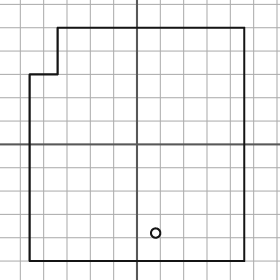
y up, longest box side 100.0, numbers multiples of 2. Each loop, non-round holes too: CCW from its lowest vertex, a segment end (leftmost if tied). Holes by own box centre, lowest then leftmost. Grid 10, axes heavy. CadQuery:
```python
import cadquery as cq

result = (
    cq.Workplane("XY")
    .moveTo(-46.0, -50.0)
    .lineTo(46.0, -50.0)
    .lineTo(46.0, 50.0)
    .lineTo(-34.0, 50.0)
    .lineTo(-34.0, 30.0)
    .lineTo(-46.0, 30.0)
    .close()
    .moveTo(8.0, -38.0)
    .circle(2.0)
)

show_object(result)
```